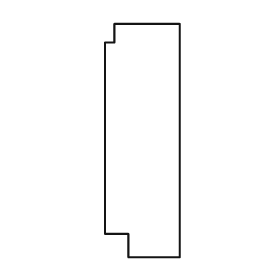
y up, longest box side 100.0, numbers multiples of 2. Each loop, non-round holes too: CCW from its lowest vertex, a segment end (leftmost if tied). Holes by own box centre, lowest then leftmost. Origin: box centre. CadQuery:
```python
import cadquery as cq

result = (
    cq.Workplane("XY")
    .moveTo(-6.0, -50.0)
    .lineTo(16.0, -50.0)
    .lineTo(16.0, 50.0)
    .lineTo(-12.0, 50.0)
    .lineTo(-12.0, 42.0)
    .lineTo(-16.0, 42.0)
    .lineTo(-16.0, -40.0)
    .lineTo(-6.0, -40.0)
    .close()
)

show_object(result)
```